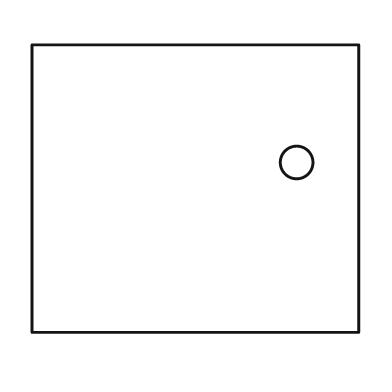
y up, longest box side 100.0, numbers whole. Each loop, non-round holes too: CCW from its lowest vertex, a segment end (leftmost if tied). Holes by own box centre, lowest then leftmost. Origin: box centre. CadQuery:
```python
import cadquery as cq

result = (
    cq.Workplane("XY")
    .moveTo(-50.0, -44.0)
    .lineTo(50.0, -44.0)
    .lineTo(50.0, 44.0)
    .lineTo(-50.0, 44.0)
    .close()
    .moveTo(31.0, 8.0)
    .circle(5.0)
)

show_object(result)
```